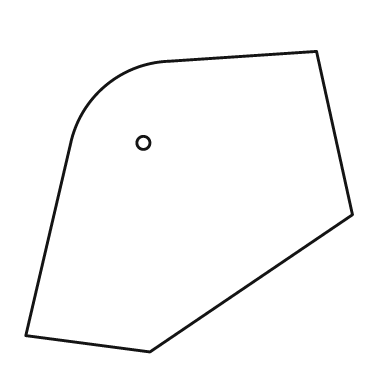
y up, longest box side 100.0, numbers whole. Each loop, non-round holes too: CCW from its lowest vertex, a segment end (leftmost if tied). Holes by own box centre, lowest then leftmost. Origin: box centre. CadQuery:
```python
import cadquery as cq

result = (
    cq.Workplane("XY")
    .moveTo(-12.0, -46.0)
    .lineTo(50.0, -4.0)
    .lineTo(39.0, 46.0)
    .lineTo(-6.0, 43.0)
    .threePointArc((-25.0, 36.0), (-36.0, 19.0))
    .lineTo(-50.0, -41.0)
    .close()
    .moveTo(-14.0, 18.0)
    .circle(2.0)
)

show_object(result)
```